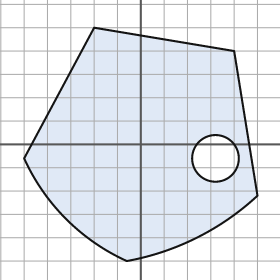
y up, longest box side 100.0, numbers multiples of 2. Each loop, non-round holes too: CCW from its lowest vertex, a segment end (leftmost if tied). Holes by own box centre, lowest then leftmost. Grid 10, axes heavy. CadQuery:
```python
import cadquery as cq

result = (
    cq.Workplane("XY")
    .moveTo(-6.0, -50.0)
    .threePointArc((24.0, -40.0), (50.0, -22.0))
    .lineTo(40.0, 40.0)
    .lineTo(-20.0, 50.0)
    .lineTo(-50.0, -6.0)
    .threePointArc((-32.0, -32.0), (-6.0, -50.0))
    .close()
    .moveTo(32.0, -6.0)
    .circle(10.0)
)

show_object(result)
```